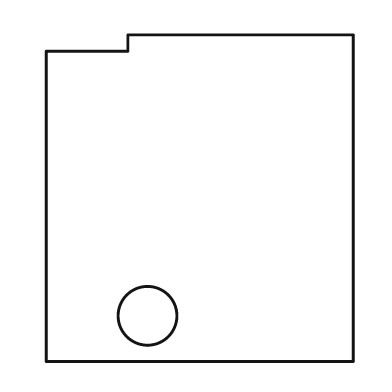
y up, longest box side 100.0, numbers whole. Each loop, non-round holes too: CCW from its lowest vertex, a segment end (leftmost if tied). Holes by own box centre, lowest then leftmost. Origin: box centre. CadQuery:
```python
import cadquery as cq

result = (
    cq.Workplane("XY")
    .moveTo(-47.0, -50.0)
    .lineTo(47.0, -50.0)
    .lineTo(47.0, 50.0)
    .lineTo(-22.0, 50.0)
    .lineTo(-22.0, 45.0)
    .lineTo(-47.0, 45.0)
    .close()
    .moveTo(-16.0, -36.0)
    .circle(9.0)
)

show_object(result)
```